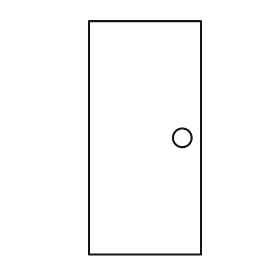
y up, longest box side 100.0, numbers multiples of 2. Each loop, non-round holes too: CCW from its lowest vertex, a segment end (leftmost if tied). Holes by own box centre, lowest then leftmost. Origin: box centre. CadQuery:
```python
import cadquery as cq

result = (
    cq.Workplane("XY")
    .moveTo(-24.0, -50.0)
    .lineTo(24.0, -50.0)
    .lineTo(24.0, 50.0)
    .lineTo(-24.0, 50.0)
    .close()
    .moveTo(16.0, 0.0)
    .circle(4.0)
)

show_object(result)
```